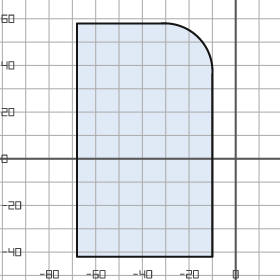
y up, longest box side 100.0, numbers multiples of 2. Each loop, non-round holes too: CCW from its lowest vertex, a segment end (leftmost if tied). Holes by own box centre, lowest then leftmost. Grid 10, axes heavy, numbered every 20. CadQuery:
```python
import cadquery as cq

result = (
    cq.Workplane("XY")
    .moveTo(-68.0, -42.0)
    .lineTo(-10.0, -42.0)
    .lineTo(-10.0, 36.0)
    .threePointArc((-16.0, 52.0), (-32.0, 58.0))
    .lineTo(-68.0, 58.0)
    .close()
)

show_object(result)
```